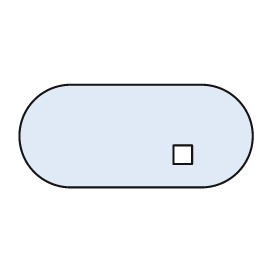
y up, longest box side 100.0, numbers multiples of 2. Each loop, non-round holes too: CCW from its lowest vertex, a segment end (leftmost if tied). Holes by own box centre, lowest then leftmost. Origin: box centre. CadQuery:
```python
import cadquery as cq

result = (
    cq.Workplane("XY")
    .moveTo(-28.0, -22.0)
    .lineTo(28.0, -22.0)
    .threePointArc((50.0, 0.0), (28.0, 22.0))
    .lineTo(-28.0, 22.0)
    .threePointArc((-50.0, 0.0), (-28.0, -22.0))
    .close()
    .moveTo(16.0, -12.0)
    .lineTo(24.0, -12.0)
    .lineTo(24.0, -4.0)
    .lineTo(16.0, -4.0)
    .close()
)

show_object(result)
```